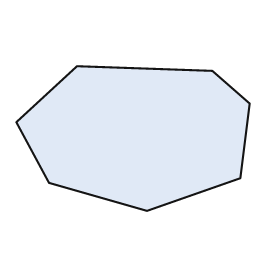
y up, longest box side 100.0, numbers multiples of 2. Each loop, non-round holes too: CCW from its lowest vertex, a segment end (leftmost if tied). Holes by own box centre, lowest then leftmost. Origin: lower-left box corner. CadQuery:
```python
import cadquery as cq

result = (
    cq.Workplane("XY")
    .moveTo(56.0, 0.0)
    .lineTo(96.0, 14.0)
    .lineTo(100.0, 46.0)
    .lineTo(84.0, 60.0)
    .lineTo(26.0, 62.0)
    .lineTo(0.0, 38.0)
    .lineTo(14.0, 12.0)
    .close()
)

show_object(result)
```